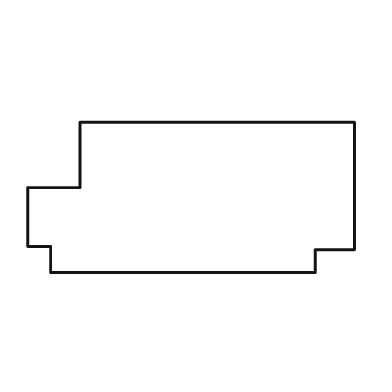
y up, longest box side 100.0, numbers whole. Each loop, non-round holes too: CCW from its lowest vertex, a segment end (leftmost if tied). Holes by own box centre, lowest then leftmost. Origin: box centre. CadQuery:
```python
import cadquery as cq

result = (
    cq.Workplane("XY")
    .moveTo(-43.0, -23.0)
    .lineTo(38.0, -23.0)
    .lineTo(38.0, -16.0)
    .lineTo(50.0, -16.0)
    .lineTo(50.0, 23.0)
    .lineTo(-34.0, 23.0)
    .lineTo(-34.0, 3.0)
    .lineTo(-50.0, 3.0)
    .lineTo(-50.0, -15.0)
    .lineTo(-43.0, -15.0)
    .close()
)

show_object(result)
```